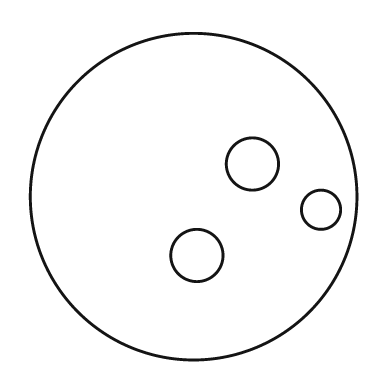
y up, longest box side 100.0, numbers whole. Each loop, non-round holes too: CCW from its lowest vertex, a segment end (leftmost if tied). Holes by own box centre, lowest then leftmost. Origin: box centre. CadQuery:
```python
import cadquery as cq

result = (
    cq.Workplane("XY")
    .moveTo(0.0, 0.0)
    .circle(50.0)
    .moveTo(1.0, -18.0)
    .circle(8.0)
    .moveTo(39.0, -4.0)
    .circle(6.0)
    .moveTo(18.0, 10.0)
    .circle(8.0)
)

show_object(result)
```